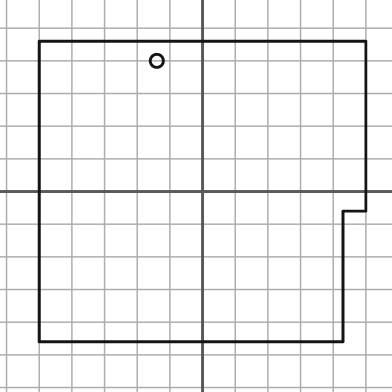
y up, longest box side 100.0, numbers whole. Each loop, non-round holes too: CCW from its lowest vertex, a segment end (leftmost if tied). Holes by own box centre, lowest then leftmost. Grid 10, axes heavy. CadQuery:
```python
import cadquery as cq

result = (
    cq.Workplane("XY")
    .moveTo(-50.0, -46.0)
    .lineTo(43.0, -46.0)
    .lineTo(43.0, -6.0)
    .lineTo(50.0, -6.0)
    .lineTo(50.0, 46.0)
    .lineTo(-50.0, 46.0)
    .close()
    .moveTo(-14.0, 40.0)
    .circle(2.0)
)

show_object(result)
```